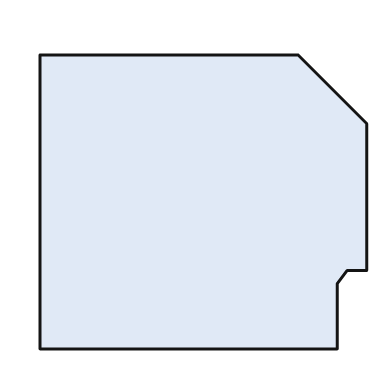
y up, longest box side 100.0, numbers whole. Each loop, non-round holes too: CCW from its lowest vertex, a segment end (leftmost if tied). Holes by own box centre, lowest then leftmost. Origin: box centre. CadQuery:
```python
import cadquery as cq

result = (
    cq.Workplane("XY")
    .moveTo(-50.0, -45.0)
    .lineTo(41.0, -45.0)
    .lineTo(41.0, -25.0)
    .lineTo(44.0, -21.0)
    .lineTo(50.0, -21.0)
    .lineTo(50.0, 24.0)
    .lineTo(29.0, 45.0)
    .lineTo(-50.0, 45.0)
    .close()
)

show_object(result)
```